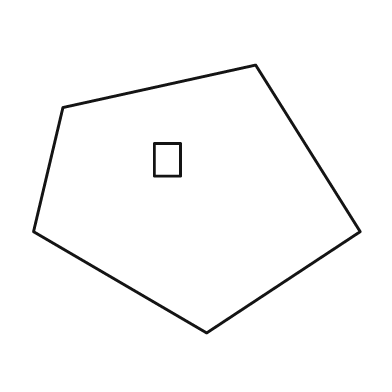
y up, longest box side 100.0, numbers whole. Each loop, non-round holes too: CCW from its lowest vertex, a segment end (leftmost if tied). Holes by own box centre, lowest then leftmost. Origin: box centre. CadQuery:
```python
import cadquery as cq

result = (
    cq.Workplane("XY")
    .moveTo(3.0, -41.0)
    .lineTo(50.0, -10.0)
    .lineTo(18.0, 41.0)
    .lineTo(-41.0, 28.0)
    .lineTo(-50.0, -10.0)
    .close()
    .moveTo(-13.0, 7.0)
    .lineTo(-5.0, 7.0)
    .lineTo(-5.0, 17.0)
    .lineTo(-13.0, 17.0)
    .close()
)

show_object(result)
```